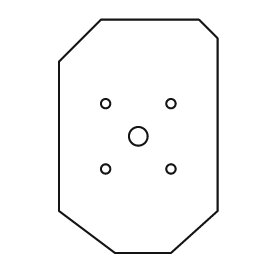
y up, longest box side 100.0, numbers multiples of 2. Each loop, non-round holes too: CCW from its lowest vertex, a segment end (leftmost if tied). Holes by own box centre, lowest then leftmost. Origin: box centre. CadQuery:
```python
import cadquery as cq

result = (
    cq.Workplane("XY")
    .moveTo(-10.0, -50.0)
    .lineTo(14.0, -50.0)
    .lineTo(34.0, -32.0)
    .lineTo(34.0, 42.0)
    .lineTo(26.0, 50.0)
    .lineTo(-16.0, 50.0)
    .lineTo(-34.0, 32.0)
    .lineTo(-34.0, -32.0)
    .close()
    .moveTo(-14.0, -14.0)
    .circle(2.0)
    .moveTo(14.0, -14.0)
    .circle(2.0)
    .moveTo(0.0, 0.0)
    .circle(4.0)
    .moveTo(-14.0, 14.0)
    .circle(2.0)
    .moveTo(14.0, 14.0)
    .circle(2.0)
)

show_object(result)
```